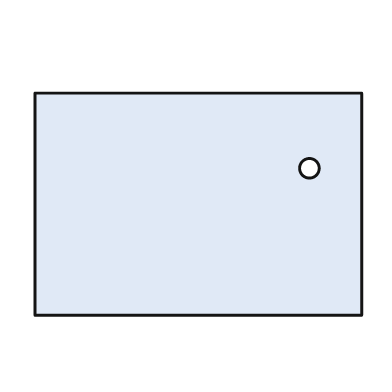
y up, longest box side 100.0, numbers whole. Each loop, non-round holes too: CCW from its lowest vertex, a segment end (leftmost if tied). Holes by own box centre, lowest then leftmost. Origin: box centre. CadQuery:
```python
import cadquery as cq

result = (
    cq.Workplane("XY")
    .moveTo(-50.0, -34.0)
    .lineTo(50.0, -34.0)
    .lineTo(50.0, 34.0)
    .lineTo(-50.0, 34.0)
    .close()
    .moveTo(34.0, 11.0)
    .circle(3.0)
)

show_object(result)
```